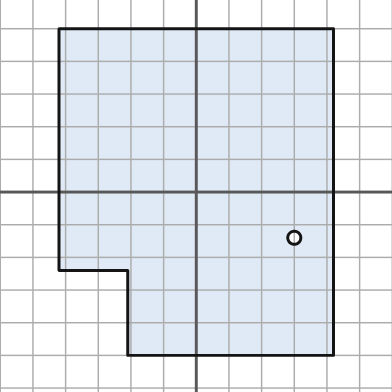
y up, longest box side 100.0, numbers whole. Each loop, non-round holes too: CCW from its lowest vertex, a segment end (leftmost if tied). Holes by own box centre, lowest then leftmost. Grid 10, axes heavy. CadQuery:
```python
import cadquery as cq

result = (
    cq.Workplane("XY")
    .moveTo(-21.0, -50.0)
    .lineTo(42.0, -50.0)
    .lineTo(42.0, 50.0)
    .lineTo(-42.0, 50.0)
    .lineTo(-42.0, -24.0)
    .lineTo(-21.0, -24.0)
    .close()
    .moveTo(30.0, -14.0)
    .circle(2.0)
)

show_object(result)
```